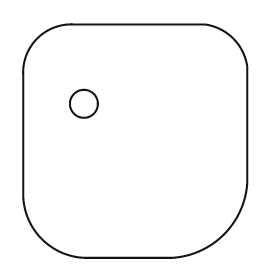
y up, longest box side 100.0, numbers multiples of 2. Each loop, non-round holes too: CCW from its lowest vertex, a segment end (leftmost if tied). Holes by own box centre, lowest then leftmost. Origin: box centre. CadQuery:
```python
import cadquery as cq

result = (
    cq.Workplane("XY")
    .moveTo(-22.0, -50.0)
    .lineTo(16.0, -50.0)
    .threePointArc((38.0, -40.0), (48.0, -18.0))
    .lineTo(48.0, 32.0)
    .threePointArc((42.0, 44.0), (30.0, 50.0))
    .lineTo(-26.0, 50.0)
    .threePointArc((-42.0, 44.0), (-48.0, 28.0))
    .lineTo(-48.0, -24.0)
    .threePointArc((-40.0, -42.0), (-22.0, -50.0))
    .close()
    .moveTo(-22.0, 16.0)
    .circle(6.0)
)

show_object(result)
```